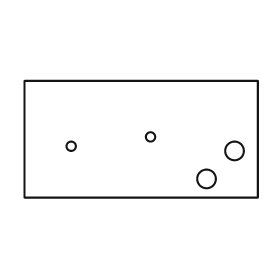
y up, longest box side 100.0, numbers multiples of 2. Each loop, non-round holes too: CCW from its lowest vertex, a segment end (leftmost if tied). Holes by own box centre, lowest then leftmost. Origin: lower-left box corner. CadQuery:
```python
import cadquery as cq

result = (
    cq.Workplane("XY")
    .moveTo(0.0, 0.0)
    .lineTo(100.0, 0.0)
    .lineTo(100.0, 50.0)
    .lineTo(0.0, 50.0)
    .close()
    .moveTo(78.0, 8.0)
    .circle(4.0)
    .moveTo(90.0, 20.0)
    .circle(4.0)
    .moveTo(20.0, 22.0)
    .circle(2.0)
    .moveTo(54.0, 26.0)
    .circle(2.0)
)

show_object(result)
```